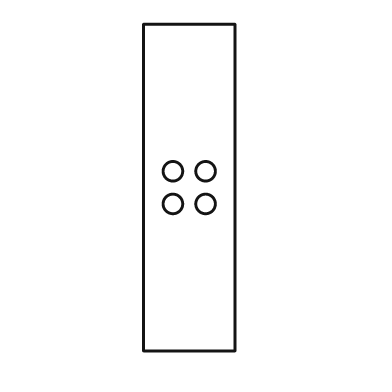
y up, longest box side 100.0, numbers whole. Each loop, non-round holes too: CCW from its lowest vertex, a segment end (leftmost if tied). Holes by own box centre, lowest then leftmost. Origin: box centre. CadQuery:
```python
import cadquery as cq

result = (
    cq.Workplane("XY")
    .moveTo(-14.0, -50.0)
    .lineTo(14.0, -50.0)
    .lineTo(14.0, 50.0)
    .lineTo(-14.0, 50.0)
    .close()
    .moveTo(-5.0, -5.0)
    .circle(3.0)
    .moveTo(5.0, -5.0)
    .circle(3.0)
    .moveTo(-5.0, 5.0)
    .circle(3.0)
    .moveTo(5.0, 5.0)
    .circle(3.0)
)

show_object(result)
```